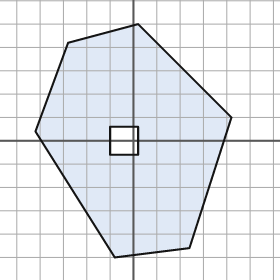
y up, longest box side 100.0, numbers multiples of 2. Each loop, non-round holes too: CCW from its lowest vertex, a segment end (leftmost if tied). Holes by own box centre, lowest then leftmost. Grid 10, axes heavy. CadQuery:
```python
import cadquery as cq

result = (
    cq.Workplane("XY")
    .moveTo(-8.0, -50.0)
    .lineTo(24.0, -46.0)
    .lineTo(42.0, 10.0)
    .lineTo(2.0, 50.0)
    .lineTo(-28.0, 42.0)
    .lineTo(-42.0, 4.0)
    .close()
    .moveTo(-10.0, -6.0)
    .lineTo(2.0, -6.0)
    .lineTo(2.0, 6.0)
    .lineTo(-10.0, 6.0)
    .close()
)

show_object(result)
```